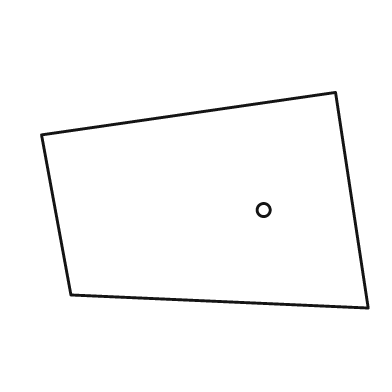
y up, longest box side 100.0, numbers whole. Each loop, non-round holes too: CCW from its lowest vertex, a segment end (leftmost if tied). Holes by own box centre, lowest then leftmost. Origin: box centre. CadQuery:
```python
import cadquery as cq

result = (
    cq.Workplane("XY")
    .moveTo(50.0, -33.0)
    .lineTo(40.0, 33.0)
    .lineTo(-50.0, 20.0)
    .lineTo(-41.0, -29.0)
    .close()
    .moveTo(18.0, -3.0)
    .circle(2.0)
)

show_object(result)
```